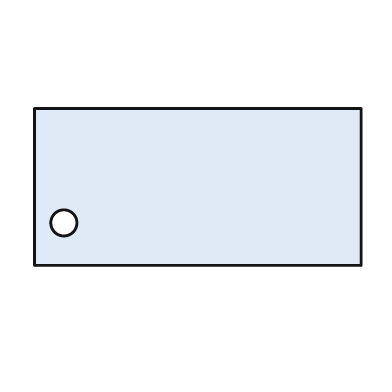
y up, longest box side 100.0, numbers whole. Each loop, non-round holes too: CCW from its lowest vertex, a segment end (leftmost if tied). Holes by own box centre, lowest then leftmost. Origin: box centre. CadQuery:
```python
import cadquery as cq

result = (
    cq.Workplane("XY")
    .moveTo(-50.0, -24.0)
    .lineTo(50.0, -24.0)
    .lineTo(50.0, 24.0)
    .lineTo(-50.0, 24.0)
    .close()
    .moveTo(-41.0, -11.0)
    .circle(4.0)
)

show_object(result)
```